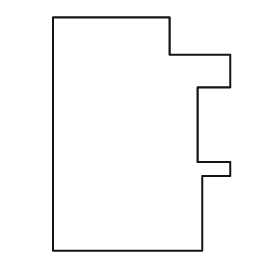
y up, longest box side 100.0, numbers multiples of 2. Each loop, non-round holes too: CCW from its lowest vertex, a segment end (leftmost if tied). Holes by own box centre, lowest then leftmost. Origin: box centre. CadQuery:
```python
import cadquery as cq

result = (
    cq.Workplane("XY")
    .moveTo(-38.0, -50.0)
    .lineTo(26.0, -50.0)
    .lineTo(26.0, -18.0)
    .lineTo(38.0, -18.0)
    .lineTo(38.0, -12.0)
    .lineTo(24.0, -12.0)
    .lineTo(24.0, 20.0)
    .lineTo(38.0, 20.0)
    .lineTo(38.0, 34.0)
    .lineTo(12.0, 34.0)
    .lineTo(12.0, 50.0)
    .lineTo(-38.0, 50.0)
    .close()
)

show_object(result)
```